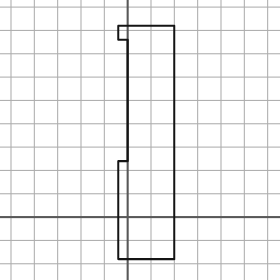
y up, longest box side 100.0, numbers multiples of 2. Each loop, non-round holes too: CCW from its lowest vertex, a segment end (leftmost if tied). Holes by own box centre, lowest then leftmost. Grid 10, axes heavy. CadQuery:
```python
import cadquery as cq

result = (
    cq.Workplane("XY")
    .moveTo(-4.0, -18.0)
    .lineTo(20.0, -18.0)
    .lineTo(20.0, 82.0)
    .lineTo(-4.0, 82.0)
    .lineTo(-4.0, 76.0)
    .lineTo(0.0, 76.0)
    .lineTo(0.0, 24.0)
    .lineTo(-4.0, 24.0)
    .close()
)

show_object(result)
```